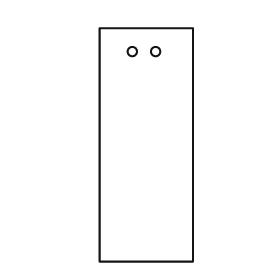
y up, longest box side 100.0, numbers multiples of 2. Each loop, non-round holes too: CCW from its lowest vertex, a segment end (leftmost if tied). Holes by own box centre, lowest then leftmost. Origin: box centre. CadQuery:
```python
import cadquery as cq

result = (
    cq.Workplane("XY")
    .moveTo(-20.0, -50.0)
    .lineTo(20.0, -50.0)
    .lineTo(20.0, 50.0)
    .lineTo(-20.0, 50.0)
    .close()
    .moveTo(-6.0, 40.0)
    .circle(2.0)
    .moveTo(4.0, 40.0)
    .circle(2.0)
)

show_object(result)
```